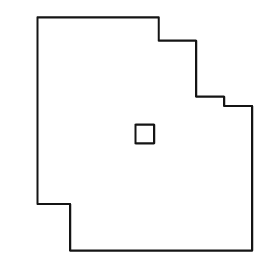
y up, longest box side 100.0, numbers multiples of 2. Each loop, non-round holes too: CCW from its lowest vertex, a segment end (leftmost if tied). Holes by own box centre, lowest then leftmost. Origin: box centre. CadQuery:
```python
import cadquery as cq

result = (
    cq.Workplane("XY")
    .moveTo(-32.0, -50.0)
    .lineTo(46.0, -50.0)
    .lineTo(46.0, 12.0)
    .lineTo(34.0, 12.0)
    .lineTo(34.0, 16.0)
    .lineTo(22.0, 16.0)
    .lineTo(22.0, 40.0)
    .lineTo(6.0, 40.0)
    .lineTo(6.0, 50.0)
    .lineTo(-46.0, 50.0)
    .lineTo(-46.0, -30.0)
    .lineTo(-32.0, -30.0)
    .close()
    .moveTo(-4.0, -4.0)
    .lineTo(4.0, -4.0)
    .lineTo(4.0, 4.0)
    .lineTo(-4.0, 4.0)
    .close()
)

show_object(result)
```